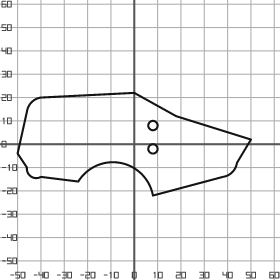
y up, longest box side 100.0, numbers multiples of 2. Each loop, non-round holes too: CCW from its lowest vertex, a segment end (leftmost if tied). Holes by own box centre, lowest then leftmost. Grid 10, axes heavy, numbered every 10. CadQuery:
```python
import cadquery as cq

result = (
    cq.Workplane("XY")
    .moveTo(8.0, -22.0)
    .lineTo(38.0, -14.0)
    .threePointArc((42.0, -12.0), (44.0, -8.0))
    .lineTo(50.0, 2.0)
    .lineTo(18.0, 12.0)
    .lineTo(0.0, 22.0)
    .lineTo(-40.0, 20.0)
    .threePointArc((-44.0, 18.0), (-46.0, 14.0))
    .lineTo(-50.0, -4.0)
    .lineTo(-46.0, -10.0)
    .threePointArc((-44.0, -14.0), (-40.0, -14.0))
    .lineTo(-24.0, -16.0)
    .threePointArc((-6.0, -8.0), (8.0, -22.0))
    .close()
    .moveTo(8.0, -2.0)
    .circle(2.0)
    .moveTo(8.0, 8.0)
    .circle(2.0)
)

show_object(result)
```